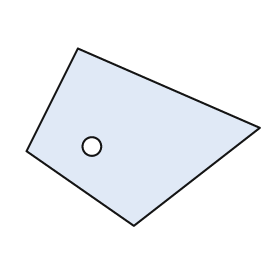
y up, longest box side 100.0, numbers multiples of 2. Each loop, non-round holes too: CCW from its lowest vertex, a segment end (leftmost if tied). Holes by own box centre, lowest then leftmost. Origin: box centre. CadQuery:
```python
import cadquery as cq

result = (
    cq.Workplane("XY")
    .moveTo(-4.0, -38.0)
    .lineTo(50.0, 4.0)
    .lineTo(-28.0, 38.0)
    .lineTo(-50.0, -6.0)
    .close()
    .moveTo(-22.0, -4.0)
    .circle(4.0)
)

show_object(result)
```